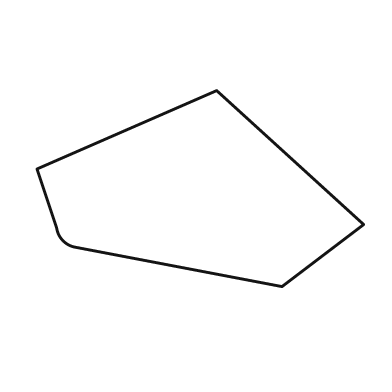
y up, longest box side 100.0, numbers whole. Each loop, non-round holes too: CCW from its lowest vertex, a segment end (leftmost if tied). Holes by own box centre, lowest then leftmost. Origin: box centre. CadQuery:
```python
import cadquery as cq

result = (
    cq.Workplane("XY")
    .moveTo(25.0, -30.0)
    .lineTo(50.0, -11.0)
    .lineTo(5.0, 30.0)
    .lineTo(-50.0, 6.0)
    .lineTo(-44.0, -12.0)
    .threePointArc((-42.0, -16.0), (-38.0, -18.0))
    .close()
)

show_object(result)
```